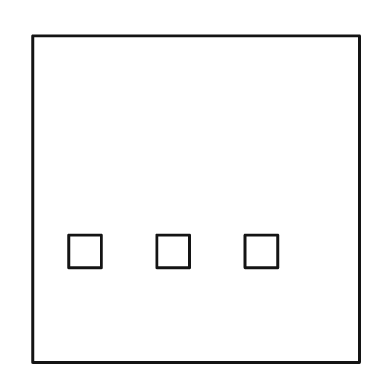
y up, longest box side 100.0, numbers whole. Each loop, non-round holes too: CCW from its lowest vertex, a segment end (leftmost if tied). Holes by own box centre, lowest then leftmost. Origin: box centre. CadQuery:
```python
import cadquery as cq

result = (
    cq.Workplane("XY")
    .moveTo(-50.0, -50.0)
    .lineTo(50.0, -50.0)
    .lineTo(50.0, 50.0)
    .lineTo(-50.0, 50.0)
    .close()
    .moveTo(-39.0, -21.0)
    .lineTo(-29.0, -21.0)
    .lineTo(-29.0, -11.0)
    .lineTo(-39.0, -11.0)
    .close()
    .moveTo(-12.0, -21.0)
    .lineTo(-2.0, -21.0)
    .lineTo(-2.0, -11.0)
    .lineTo(-12.0, -11.0)
    .close()
    .moveTo(15.0, -21.0)
    .lineTo(25.0, -21.0)
    .lineTo(25.0, -11.0)
    .lineTo(15.0, -11.0)
    .close()
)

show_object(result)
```